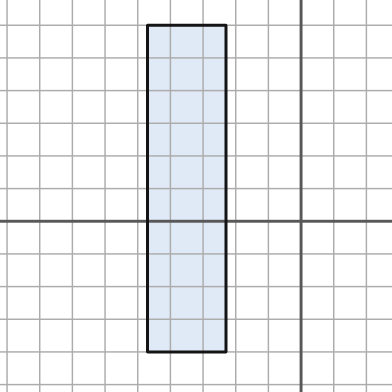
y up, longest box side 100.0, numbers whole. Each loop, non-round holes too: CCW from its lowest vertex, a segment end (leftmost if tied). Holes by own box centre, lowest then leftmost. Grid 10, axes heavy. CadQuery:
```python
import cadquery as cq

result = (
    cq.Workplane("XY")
    .moveTo(-47.0, -40.0)
    .lineTo(-23.0, -40.0)
    .lineTo(-23.0, 60.0)
    .lineTo(-47.0, 60.0)
    .close()
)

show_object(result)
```